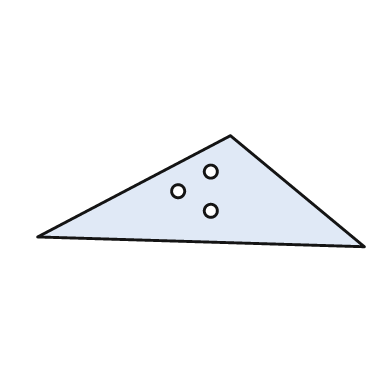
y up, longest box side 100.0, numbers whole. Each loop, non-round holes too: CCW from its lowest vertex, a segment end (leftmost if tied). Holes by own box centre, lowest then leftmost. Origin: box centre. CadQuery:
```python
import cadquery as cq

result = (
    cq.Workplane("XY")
    .moveTo(50.0, -17.0)
    .lineTo(9.0, 17.0)
    .lineTo(-50.0, -14.0)
    .close()
    .moveTo(3.0, -6.0)
    .circle(2.0)
    .moveTo(-7.0, 0.0)
    .circle(2.0)
    .moveTo(3.0, 6.0)
    .circle(2.0)
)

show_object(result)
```